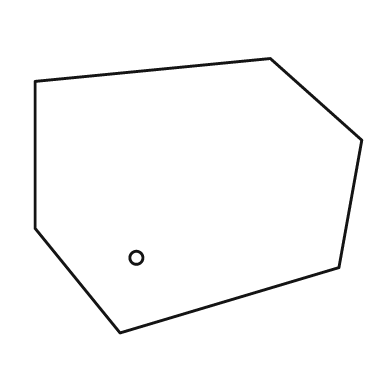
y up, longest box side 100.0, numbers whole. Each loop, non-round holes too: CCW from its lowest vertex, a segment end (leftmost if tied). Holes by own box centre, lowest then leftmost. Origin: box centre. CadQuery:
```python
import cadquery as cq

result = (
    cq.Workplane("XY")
    .moveTo(-24.0, -42.0)
    .lineTo(43.0, -22.0)
    .lineTo(50.0, 17.0)
    .lineTo(22.0, 42.0)
    .lineTo(-50.0, 35.0)
    .lineTo(-50.0, -10.0)
    .close()
    .moveTo(-19.0, -19.0)
    .circle(2.0)
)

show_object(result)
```